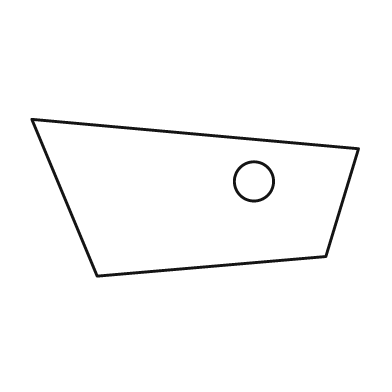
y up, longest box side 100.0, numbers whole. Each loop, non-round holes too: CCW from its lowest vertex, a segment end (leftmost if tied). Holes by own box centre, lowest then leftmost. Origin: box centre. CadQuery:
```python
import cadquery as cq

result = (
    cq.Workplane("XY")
    .moveTo(-30.0, -24.0)
    .lineTo(40.0, -18.0)
    .lineTo(50.0, 15.0)
    .lineTo(-50.0, 24.0)
    .close()
    .moveTo(18.0, 5.0)
    .circle(6.0)
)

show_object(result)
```